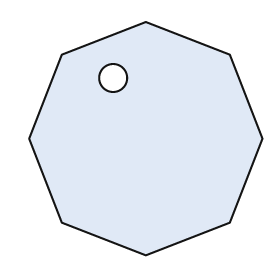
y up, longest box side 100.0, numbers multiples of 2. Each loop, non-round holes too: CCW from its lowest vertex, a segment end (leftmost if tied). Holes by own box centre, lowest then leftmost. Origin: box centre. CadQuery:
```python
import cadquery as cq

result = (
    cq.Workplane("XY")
    .moveTo(0.0, -50.0)
    .lineTo(36.0, -36.0)
    .lineTo(50.0, 0.0)
    .lineTo(36.0, 36.0)
    .lineTo(0.0, 50.0)
    .lineTo(-36.0, 36.0)
    .lineTo(-50.0, 0.0)
    .lineTo(-36.0, -36.0)
    .close()
    .moveTo(-14.0, 26.0)
    .circle(6.0)
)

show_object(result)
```